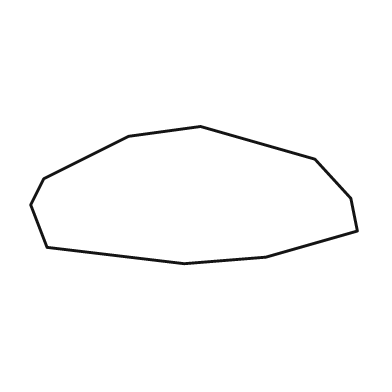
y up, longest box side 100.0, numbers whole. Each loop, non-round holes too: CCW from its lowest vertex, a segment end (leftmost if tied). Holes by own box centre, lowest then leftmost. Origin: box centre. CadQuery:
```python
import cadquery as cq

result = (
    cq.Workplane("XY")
    .moveTo(-3.0, -21.0)
    .lineTo(22.0, -19.0)
    .lineTo(50.0, -11.0)
    .lineTo(48.0, -1.0)
    .lineTo(37.0, 11.0)
    .lineTo(2.0, 21.0)
    .lineTo(-20.0, 18.0)
    .lineTo(-46.0, 5.0)
    .lineTo(-50.0, -3.0)
    .lineTo(-45.0, -16.0)
    .close()
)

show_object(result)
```